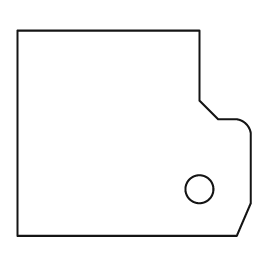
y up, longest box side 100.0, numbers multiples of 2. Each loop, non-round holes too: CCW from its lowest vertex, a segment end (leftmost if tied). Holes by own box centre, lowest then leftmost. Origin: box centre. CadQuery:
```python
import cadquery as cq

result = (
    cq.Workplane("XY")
    .moveTo(-50.0, -44.0)
    .lineTo(44.0, -44.0)
    .lineTo(50.0, -30.0)
    .lineTo(50.0, 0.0)
    .threePointArc((48.0, 4.0), (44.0, 6.0))
    .lineTo(36.0, 6.0)
    .lineTo(28.0, 14.0)
    .lineTo(28.0, 44.0)
    .lineTo(-50.0, 44.0)
    .close()
    .moveTo(28.0, -24.0)
    .circle(6.0)
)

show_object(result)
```